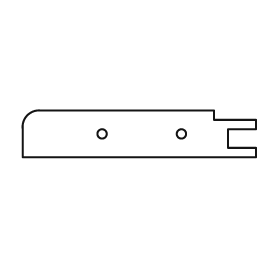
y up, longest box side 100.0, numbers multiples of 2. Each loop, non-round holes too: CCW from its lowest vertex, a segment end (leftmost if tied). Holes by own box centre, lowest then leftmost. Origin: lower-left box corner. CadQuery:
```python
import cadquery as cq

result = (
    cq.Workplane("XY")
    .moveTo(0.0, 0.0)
    .lineTo(100.0, 0.0)
    .lineTo(100.0, 4.0)
    .lineTo(88.0, 4.0)
    .lineTo(88.0, 12.0)
    .lineTo(100.0, 12.0)
    .lineTo(100.0, 16.0)
    .lineTo(82.0, 16.0)
    .lineTo(82.0, 20.0)
    .lineTo(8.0, 20.0)
    .threePointArc((2.0, 18.0), (0.0, 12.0))
    .close()
    .moveTo(34.0, 10.0)
    .circle(2.0)
    .moveTo(68.0, 10.0)
    .circle(2.0)
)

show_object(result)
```